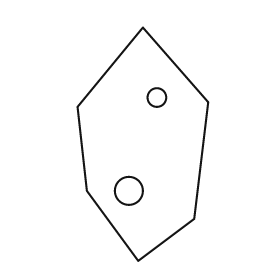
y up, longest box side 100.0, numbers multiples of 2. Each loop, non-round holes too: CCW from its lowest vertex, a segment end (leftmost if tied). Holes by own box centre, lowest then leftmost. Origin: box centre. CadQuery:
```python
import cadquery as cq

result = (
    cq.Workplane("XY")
    .moveTo(-2.0, -50.0)
    .lineTo(22.0, -32.0)
    .lineTo(28.0, 18.0)
    .lineTo(0.0, 50.0)
    .lineTo(-28.0, 16.0)
    .lineTo(-24.0, -20.0)
    .close()
    .moveTo(-6.0, -20.0)
    .circle(6.0)
    .moveTo(6.0, 20.0)
    .circle(4.0)
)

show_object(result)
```